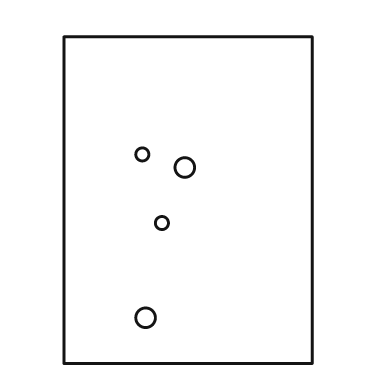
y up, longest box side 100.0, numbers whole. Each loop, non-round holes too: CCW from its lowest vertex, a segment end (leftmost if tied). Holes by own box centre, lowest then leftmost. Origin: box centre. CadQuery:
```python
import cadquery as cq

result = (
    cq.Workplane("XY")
    .moveTo(-38.0, -50.0)
    .lineTo(38.0, -50.0)
    .lineTo(38.0, 50.0)
    .lineTo(-38.0, 50.0)
    .close()
    .moveTo(-13.0, -36.0)
    .circle(3.0)
    .moveTo(-8.0, -7.0)
    .circle(2.0)
    .moveTo(-1.0, 10.0)
    .circle(3.0)
    .moveTo(-14.0, 14.0)
    .circle(2.0)
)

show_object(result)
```